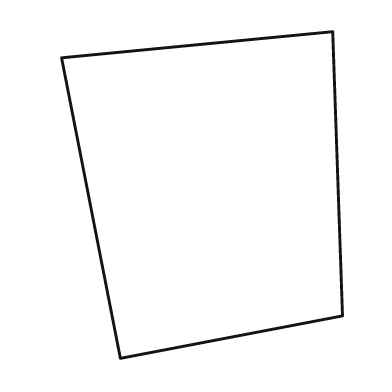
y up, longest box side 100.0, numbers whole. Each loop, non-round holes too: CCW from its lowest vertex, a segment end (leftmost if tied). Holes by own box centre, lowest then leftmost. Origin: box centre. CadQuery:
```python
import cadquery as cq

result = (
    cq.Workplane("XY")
    .moveTo(-25.0, -50.0)
    .lineTo(43.0, -37.0)
    .lineTo(40.0, 50.0)
    .lineTo(-43.0, 42.0)
    .close()
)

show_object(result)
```